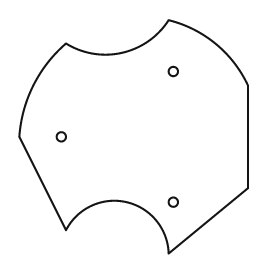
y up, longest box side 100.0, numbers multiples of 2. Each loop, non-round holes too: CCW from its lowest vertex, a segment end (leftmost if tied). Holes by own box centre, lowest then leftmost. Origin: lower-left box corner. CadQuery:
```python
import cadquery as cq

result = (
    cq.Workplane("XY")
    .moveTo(64.0, 0.0)
    .lineTo(98.0, 28.0)
    .lineTo(98.0, 72.0)
    .threePointArc((84.0, 90.0), (64.0, 100.0))
    .threePointArc((44.0, 86.0), (20.0, 90.0))
    .threePointArc((6.0, 72.0), (0.0, 50.0))
    .lineTo(20.0, 10.0)
    .threePointArc((46.0, 22.0), (64.0, 0.0))
    .close()
    .moveTo(66.0, 22.0)
    .circle(2.0)
    .moveTo(18.0, 50.0)
    .circle(2.0)
    .moveTo(66.0, 78.0)
    .circle(2.0)
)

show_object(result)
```